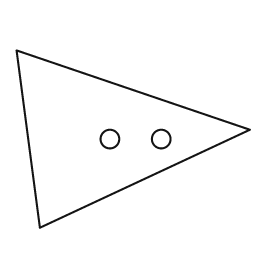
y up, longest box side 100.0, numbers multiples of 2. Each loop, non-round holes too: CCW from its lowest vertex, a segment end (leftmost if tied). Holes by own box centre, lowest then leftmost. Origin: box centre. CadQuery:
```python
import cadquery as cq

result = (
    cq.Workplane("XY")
    .moveTo(-40.0, -38.0)
    .lineTo(50.0, 4.0)
    .lineTo(-50.0, 38.0)
    .close()
    .moveTo(-10.0, 0.0)
    .circle(4.0)
    .moveTo(12.0, 0.0)
    .circle(4.0)
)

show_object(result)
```